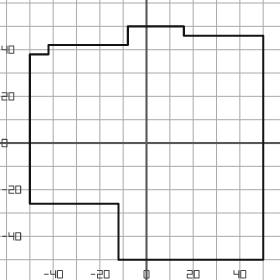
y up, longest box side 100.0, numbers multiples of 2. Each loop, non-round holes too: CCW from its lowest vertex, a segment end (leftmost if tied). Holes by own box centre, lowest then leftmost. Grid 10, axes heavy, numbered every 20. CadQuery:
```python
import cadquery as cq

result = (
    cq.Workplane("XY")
    .moveTo(-12.0, -50.0)
    .lineTo(50.0, -50.0)
    .lineTo(50.0, 46.0)
    .lineTo(16.0, 46.0)
    .lineTo(16.0, 50.0)
    .lineTo(-8.0, 50.0)
    .lineTo(-8.0, 42.0)
    .lineTo(-42.0, 42.0)
    .lineTo(-42.0, 38.0)
    .lineTo(-50.0, 38.0)
    .lineTo(-50.0, -26.0)
    .lineTo(-12.0, -26.0)
    .close()
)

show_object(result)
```